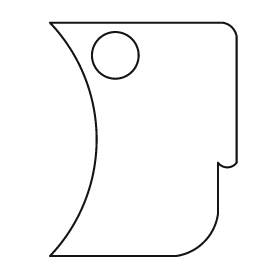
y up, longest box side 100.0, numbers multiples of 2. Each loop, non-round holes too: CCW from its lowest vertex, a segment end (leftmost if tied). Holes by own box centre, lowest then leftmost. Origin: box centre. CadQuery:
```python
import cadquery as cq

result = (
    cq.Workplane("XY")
    .moveTo(-40.0, -50.0)
    .lineTo(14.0, -50.0)
    .threePointArc((26.0, -44.0), (32.0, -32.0))
    .lineTo(32.0, -10.0)
    .threePointArc((36.0, -12.0), (40.0, -10.0))
    .lineTo(40.0, 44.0)
    .threePointArc((38.0, 48.0), (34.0, 50.0))
    .lineTo(-40.0, 50.0)
    .threePointArc((-20.0, 0.0), (-40.0, -50.0))
    .close()
    .moveTo(-12.0, 36.0)
    .circle(10.0)
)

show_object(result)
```